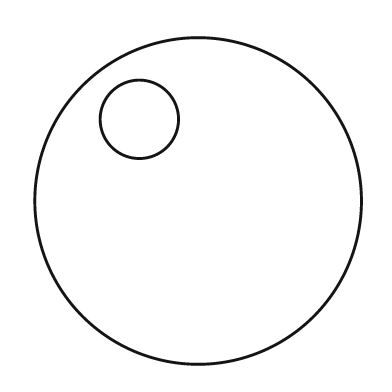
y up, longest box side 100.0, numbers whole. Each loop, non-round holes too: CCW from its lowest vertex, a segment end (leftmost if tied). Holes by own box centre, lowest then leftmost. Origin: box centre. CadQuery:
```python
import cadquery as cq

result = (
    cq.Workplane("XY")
    .moveTo(0.0, 0.0)
    .circle(50.0)
    .moveTo(-18.0, 25.0)
    .circle(12.0)
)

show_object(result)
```